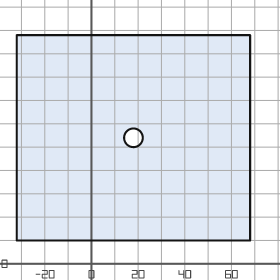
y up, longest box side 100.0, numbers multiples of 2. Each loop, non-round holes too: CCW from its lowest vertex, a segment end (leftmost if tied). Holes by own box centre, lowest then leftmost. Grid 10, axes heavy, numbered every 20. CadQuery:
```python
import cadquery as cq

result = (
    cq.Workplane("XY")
    .moveTo(-32.0, 10.0)
    .lineTo(68.0, 10.0)
    .lineTo(68.0, 98.0)
    .lineTo(-32.0, 98.0)
    .close()
    .moveTo(18.0, 54.0)
    .circle(4.0)
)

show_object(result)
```